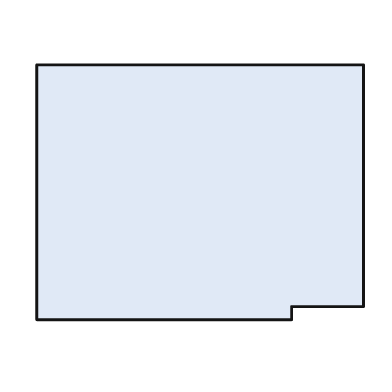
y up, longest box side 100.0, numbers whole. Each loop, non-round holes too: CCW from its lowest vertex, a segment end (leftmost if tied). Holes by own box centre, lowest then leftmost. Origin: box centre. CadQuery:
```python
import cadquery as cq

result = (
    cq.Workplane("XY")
    .moveTo(-50.0, -39.0)
    .lineTo(28.0, -39.0)
    .lineTo(28.0, -35.0)
    .lineTo(50.0, -35.0)
    .lineTo(50.0, 39.0)
    .lineTo(-50.0, 39.0)
    .close()
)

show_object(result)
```